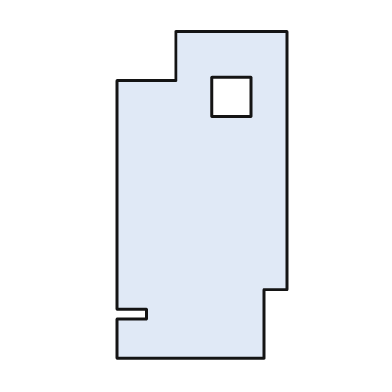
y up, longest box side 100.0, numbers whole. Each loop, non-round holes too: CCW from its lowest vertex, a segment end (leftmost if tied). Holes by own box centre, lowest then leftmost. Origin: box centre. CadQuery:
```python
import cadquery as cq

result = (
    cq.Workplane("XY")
    .moveTo(-26.0, -50.0)
    .lineTo(19.0, -50.0)
    .lineTo(19.0, -29.0)
    .lineTo(26.0, -29.0)
    .lineTo(26.0, 50.0)
    .lineTo(-8.0, 50.0)
    .lineTo(-8.0, 35.0)
    .lineTo(-26.0, 35.0)
    .lineTo(-26.0, -35.0)
    .lineTo(-17.0, -35.0)
    .lineTo(-17.0, -38.0)
    .lineTo(-26.0, -38.0)
    .close()
    .moveTo(3.0, 24.0)
    .lineTo(15.0, 24.0)
    .lineTo(15.0, 36.0)
    .lineTo(3.0, 36.0)
    .close()
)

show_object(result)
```